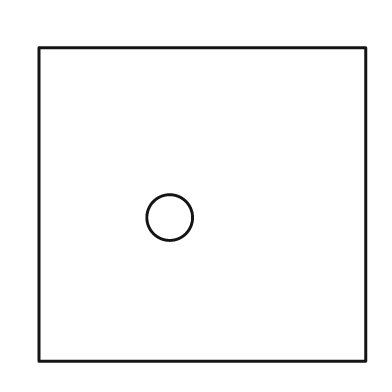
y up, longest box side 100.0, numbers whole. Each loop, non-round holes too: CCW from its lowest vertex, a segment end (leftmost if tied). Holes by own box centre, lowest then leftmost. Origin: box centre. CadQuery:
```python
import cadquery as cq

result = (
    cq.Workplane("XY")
    .moveTo(-50.0, -48.0)
    .lineTo(50.0, -48.0)
    .lineTo(50.0, 48.0)
    .lineTo(-50.0, 48.0)
    .close()
    .moveTo(-10.0, -4.0)
    .circle(7.0)
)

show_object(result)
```